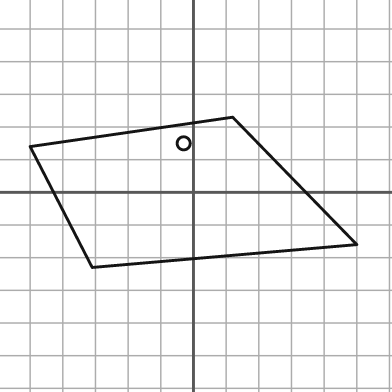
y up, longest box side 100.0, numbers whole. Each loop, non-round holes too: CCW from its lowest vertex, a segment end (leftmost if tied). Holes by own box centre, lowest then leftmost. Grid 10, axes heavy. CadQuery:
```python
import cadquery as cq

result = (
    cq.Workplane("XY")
    .moveTo(-31.0, -23.0)
    .lineTo(50.0, -16.0)
    .lineTo(12.0, 23.0)
    .lineTo(-50.0, 14.0)
    .close()
    .moveTo(-3.0, 15.0)
    .circle(2.0)
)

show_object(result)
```